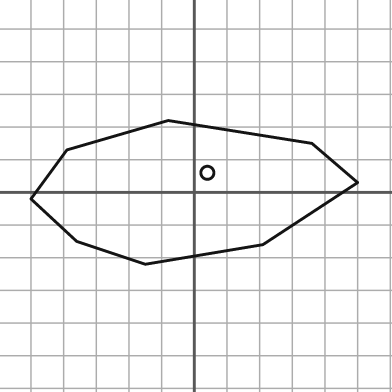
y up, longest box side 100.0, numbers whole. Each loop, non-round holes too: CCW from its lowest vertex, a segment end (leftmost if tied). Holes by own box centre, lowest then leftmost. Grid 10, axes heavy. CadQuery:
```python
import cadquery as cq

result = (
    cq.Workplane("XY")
    .moveTo(-15.0, -22.0)
    .lineTo(21.0, -16.0)
    .lineTo(50.0, 3.0)
    .lineTo(36.0, 15.0)
    .lineTo(-8.0, 22.0)
    .lineTo(-39.0, 13.0)
    .lineTo(-50.0, -2.0)
    .lineTo(-36.0, -15.0)
    .close()
    .moveTo(4.0, 6.0)
    .circle(2.0)
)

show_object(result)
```